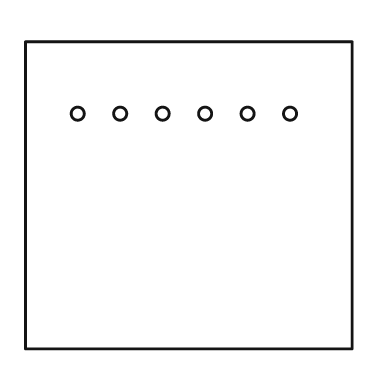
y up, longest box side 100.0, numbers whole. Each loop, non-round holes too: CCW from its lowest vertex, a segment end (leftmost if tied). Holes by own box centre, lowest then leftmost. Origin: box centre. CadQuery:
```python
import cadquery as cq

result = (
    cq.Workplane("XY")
    .moveTo(-50.0, -47.0)
    .lineTo(50.0, -47.0)
    .lineTo(50.0, 47.0)
    .lineTo(-50.0, 47.0)
    .close()
    .moveTo(-34.0, 25.0)
    .circle(2.0)
    .moveTo(-21.0, 25.0)
    .circle(2.0)
    .moveTo(-8.0, 25.0)
    .circle(2.0)
    .moveTo(5.0, 25.0)
    .circle(2.0)
    .moveTo(18.0, 25.0)
    .circle(2.0)
    .moveTo(31.0, 25.0)
    .circle(2.0)
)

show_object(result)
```